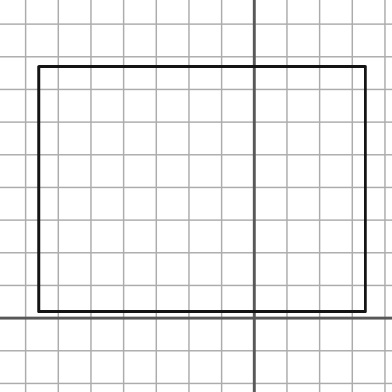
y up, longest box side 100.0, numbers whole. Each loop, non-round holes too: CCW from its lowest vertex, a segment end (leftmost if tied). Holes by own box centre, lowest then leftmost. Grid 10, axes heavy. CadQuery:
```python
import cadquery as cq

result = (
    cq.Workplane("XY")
    .moveTo(-66.0, 2.0)
    .lineTo(34.0, 2.0)
    .lineTo(34.0, 77.0)
    .lineTo(-66.0, 77.0)
    .close()
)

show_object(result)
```